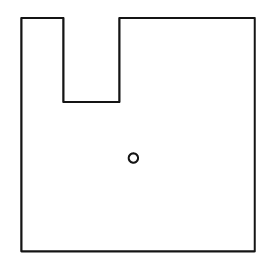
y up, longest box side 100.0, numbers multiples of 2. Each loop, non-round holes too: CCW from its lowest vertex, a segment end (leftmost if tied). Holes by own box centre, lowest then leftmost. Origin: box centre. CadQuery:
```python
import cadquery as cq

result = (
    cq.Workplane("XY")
    .moveTo(-50.0, -50.0)
    .lineTo(50.0, -50.0)
    .lineTo(50.0, 50.0)
    .lineTo(-8.0, 50.0)
    .lineTo(-8.0, 14.0)
    .lineTo(-32.0, 14.0)
    .lineTo(-32.0, 50.0)
    .lineTo(-50.0, 50.0)
    .close()
    .moveTo(-2.0, -10.0)
    .circle(2.0)
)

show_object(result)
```